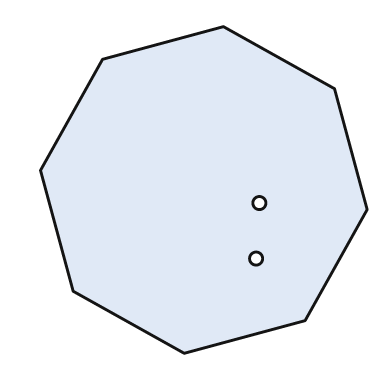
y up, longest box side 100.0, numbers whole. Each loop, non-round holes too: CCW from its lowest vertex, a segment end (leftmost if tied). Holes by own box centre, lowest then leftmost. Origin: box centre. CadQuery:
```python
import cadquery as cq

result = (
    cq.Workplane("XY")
    .moveTo(-6.0, -50.0)
    .lineTo(31.0, -40.0)
    .lineTo(50.0, -6.0)
    .lineTo(40.0, 31.0)
    .lineTo(6.0, 50.0)
    .lineTo(-31.0, 40.0)
    .lineTo(-50.0, 6.0)
    .lineTo(-40.0, -31.0)
    .close()
    .moveTo(16.0, -21.0)
    .circle(2.0)
    .moveTo(17.0, -4.0)
    .circle(2.0)
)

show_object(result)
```